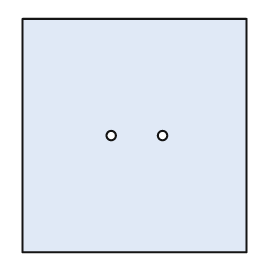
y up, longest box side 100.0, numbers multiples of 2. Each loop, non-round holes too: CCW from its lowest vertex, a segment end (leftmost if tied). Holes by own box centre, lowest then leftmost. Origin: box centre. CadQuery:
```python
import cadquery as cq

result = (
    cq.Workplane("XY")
    .moveTo(-48.0, -50.0)
    .lineTo(48.0, -50.0)
    .lineTo(48.0, 50.0)
    .lineTo(-48.0, 50.0)
    .close()
    .moveTo(-10.0, 0.0)
    .circle(2.0)
    .moveTo(12.0, 0.0)
    .circle(2.0)
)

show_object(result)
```